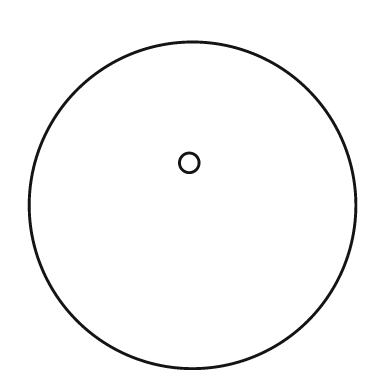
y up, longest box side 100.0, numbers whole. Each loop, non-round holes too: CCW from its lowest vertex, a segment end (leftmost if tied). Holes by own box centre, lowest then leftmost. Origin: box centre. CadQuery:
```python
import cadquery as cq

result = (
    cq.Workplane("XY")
    .moveTo(0.0, 0.0)
    .circle(50.0)
    .moveTo(-1.0, 13.0)
    .circle(3.0)
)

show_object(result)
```